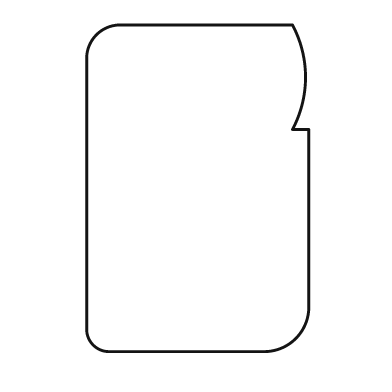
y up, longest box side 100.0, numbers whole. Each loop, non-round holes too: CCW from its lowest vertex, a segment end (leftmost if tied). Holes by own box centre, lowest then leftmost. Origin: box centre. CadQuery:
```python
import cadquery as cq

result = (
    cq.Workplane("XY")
    .moveTo(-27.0, -50.0)
    .lineTo(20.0, -50.0)
    .threePointArc((30.0, -46.0), (34.0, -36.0))
    .lineTo(34.0, 18.0)
    .lineTo(29.0, 18.0)
    .threePointArc((33.0, 34.0), (29.0, 50.0))
    .lineTo(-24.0, 50.0)
    .threePointArc((-31.0, 47.0), (-34.0, 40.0))
    .lineTo(-34.0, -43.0)
    .threePointArc((-32.0, -48.0), (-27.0, -50.0))
    .close()
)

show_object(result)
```